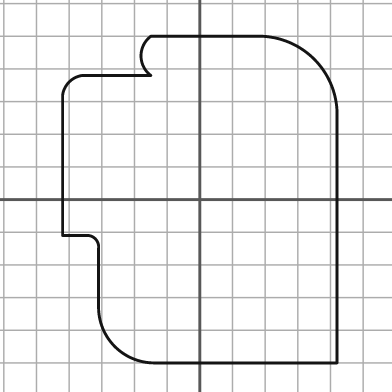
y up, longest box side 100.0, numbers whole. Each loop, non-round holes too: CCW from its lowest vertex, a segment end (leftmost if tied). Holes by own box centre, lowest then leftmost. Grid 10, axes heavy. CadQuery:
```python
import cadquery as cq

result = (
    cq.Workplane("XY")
    .moveTo(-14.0, -50.0)
    .lineTo(42.0, -50.0)
    .lineTo(42.0, 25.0)
    .threePointArc((35.0, 43.0), (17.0, 50.0))
    .lineTo(-15.0, 50.0)
    .threePointArc((-18.0, 44.0), (-15.0, 38.0))
    .lineTo(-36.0, 38.0)
    .threePointArc((-40.0, 36.0), (-42.0, 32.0))
    .lineTo(-42.0, -11.0)
    .lineTo(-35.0, -11.0)
    .threePointArc((-32.0, -12.0), (-31.0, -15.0))
    .lineTo(-31.0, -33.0)
    .threePointArc((-26.0, -45.0), (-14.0, -50.0))
    .close()
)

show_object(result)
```